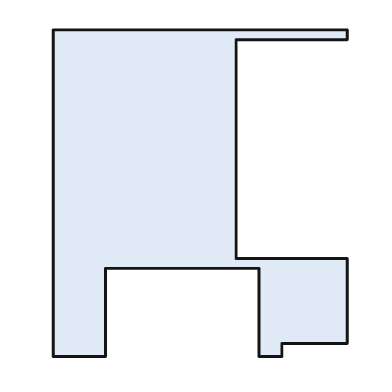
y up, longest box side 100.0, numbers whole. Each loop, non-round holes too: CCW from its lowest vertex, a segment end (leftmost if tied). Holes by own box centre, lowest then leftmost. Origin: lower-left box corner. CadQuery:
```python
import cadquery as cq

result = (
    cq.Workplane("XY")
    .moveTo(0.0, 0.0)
    .lineTo(16.0, 0.0)
    .lineTo(16.0, 27.0)
    .lineTo(63.0, 27.0)
    .lineTo(63.0, 0.0)
    .lineTo(70.0, 0.0)
    .lineTo(70.0, 4.0)
    .lineTo(90.0, 4.0)
    .lineTo(90.0, 30.0)
    .lineTo(56.0, 30.0)
    .lineTo(56.0, 97.0)
    .lineTo(90.0, 97.0)
    .lineTo(90.0, 100.0)
    .lineTo(0.0, 100.0)
    .close()
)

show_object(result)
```